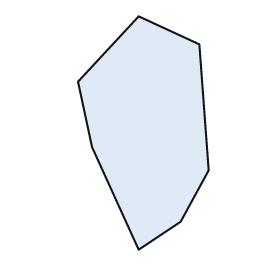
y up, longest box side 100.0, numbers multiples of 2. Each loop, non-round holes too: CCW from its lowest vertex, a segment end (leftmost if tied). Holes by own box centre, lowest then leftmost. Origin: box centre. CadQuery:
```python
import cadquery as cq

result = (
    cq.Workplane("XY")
    .moveTo(-2.0, -50.0)
    .lineTo(16.0, -38.0)
    .lineTo(28.0, -16.0)
    .lineTo(24.0, 38.0)
    .lineTo(-2.0, 50.0)
    .lineTo(-28.0, 22.0)
    .lineTo(-22.0, -6.0)
    .close()
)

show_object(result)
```